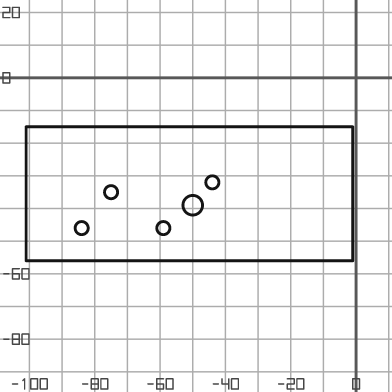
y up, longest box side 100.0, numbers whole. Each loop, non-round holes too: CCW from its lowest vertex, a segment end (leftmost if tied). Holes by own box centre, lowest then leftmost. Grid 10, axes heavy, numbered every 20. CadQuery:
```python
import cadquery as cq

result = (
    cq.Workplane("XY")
    .moveTo(-101.0, -56.0)
    .lineTo(-1.0, -56.0)
    .lineTo(-1.0, -15.0)
    .lineTo(-101.0, -15.0)
    .close()
    .moveTo(-84.0, -46.0)
    .circle(2.0)
    .moveTo(-59.0, -46.0)
    .circle(2.0)
    .moveTo(-50.0, -39.0)
    .circle(3.0)
    .moveTo(-75.0, -35.0)
    .circle(2.0)
    .moveTo(-44.0, -32.0)
    .circle(2.0)
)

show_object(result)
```